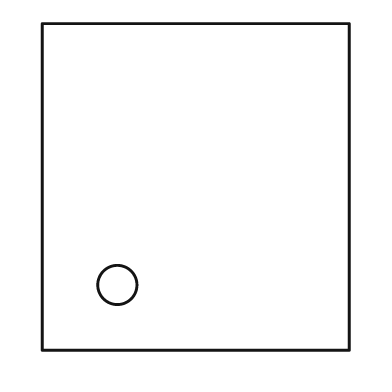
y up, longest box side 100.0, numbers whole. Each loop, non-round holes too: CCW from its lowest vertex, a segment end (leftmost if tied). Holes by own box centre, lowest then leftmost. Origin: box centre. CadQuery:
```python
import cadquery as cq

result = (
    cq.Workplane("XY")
    .moveTo(-47.0, -50.0)
    .lineTo(47.0, -50.0)
    .lineTo(47.0, 50.0)
    .lineTo(-47.0, 50.0)
    .close()
    .moveTo(-24.0, -30.0)
    .circle(6.0)
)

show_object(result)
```